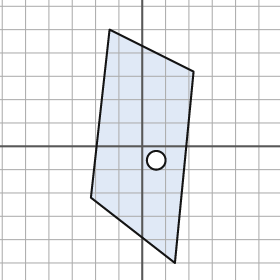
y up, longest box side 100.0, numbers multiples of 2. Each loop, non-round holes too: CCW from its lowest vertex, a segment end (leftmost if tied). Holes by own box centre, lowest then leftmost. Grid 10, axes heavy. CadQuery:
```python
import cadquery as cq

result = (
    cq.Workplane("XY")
    .moveTo(14.0, -50.0)
    .lineTo(22.0, 32.0)
    .lineTo(-14.0, 50.0)
    .lineTo(-22.0, -22.0)
    .close()
    .moveTo(6.0, -6.0)
    .circle(4.0)
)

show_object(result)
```